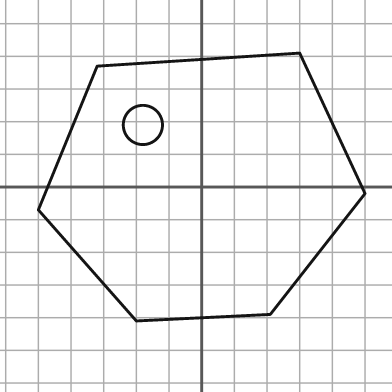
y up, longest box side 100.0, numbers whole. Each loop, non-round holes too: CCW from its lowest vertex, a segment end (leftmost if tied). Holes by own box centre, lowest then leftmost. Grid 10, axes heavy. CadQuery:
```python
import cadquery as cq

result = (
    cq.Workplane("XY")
    .moveTo(-20.0, -41.0)
    .lineTo(21.0, -39.0)
    .lineTo(50.0, -2.0)
    .lineTo(30.0, 41.0)
    .lineTo(-32.0, 37.0)
    .lineTo(-50.0, -7.0)
    .close()
    .moveTo(-18.0, 19.0)
    .circle(6.0)
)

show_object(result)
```